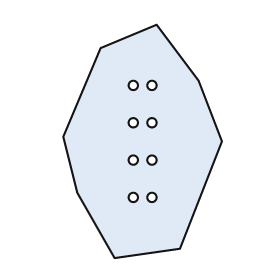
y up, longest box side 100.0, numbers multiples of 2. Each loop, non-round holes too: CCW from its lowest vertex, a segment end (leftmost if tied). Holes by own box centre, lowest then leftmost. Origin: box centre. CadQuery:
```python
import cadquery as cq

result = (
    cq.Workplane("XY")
    .moveTo(-12.0, -50.0)
    .lineTo(16.0, -46.0)
    .lineTo(34.0, 0.0)
    .lineTo(24.0, 26.0)
    .lineTo(6.0, 50.0)
    .lineTo(-18.0, 40.0)
    .lineTo(-34.0, 2.0)
    .lineTo(-28.0, -22.0)
    .close()
    .moveTo(-4.0, -24.0)
    .circle(2.0)
    .moveTo(4.0, -24.0)
    .circle(2.0)
    .moveTo(-4.0, -8.0)
    .circle(2.0)
    .moveTo(4.0, -8.0)
    .circle(2.0)
    .moveTo(-4.0, 8.0)
    .circle(2.0)
    .moveTo(4.0, 8.0)
    .circle(2.0)
    .moveTo(-4.0, 24.0)
    .circle(2.0)
    .moveTo(4.0, 24.0)
    .circle(2.0)
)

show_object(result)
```